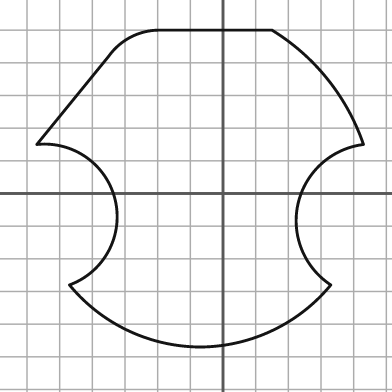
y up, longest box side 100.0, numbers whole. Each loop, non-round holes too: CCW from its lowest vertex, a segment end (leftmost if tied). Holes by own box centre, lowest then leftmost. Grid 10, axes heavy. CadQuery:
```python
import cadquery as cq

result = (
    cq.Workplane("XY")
    .moveTo(-7.0, -47.0)
    .threePointArc((15.0, -42.0), (33.0, -28.0))
    .threePointArc((23.0, -3.0), (43.0, 15.0))
    .threePointArc((32.0, 35.0), (15.0, 50.0))
    .lineTo(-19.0, 50.0)
    .threePointArc((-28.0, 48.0), (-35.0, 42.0))
    .lineTo(-57.0, 15.0)
    .threePointArc((-33.0, -2.0), (-47.0, -28.0))
    .threePointArc((-29.0, -42.0), (-7.0, -47.0))
    .close()
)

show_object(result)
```